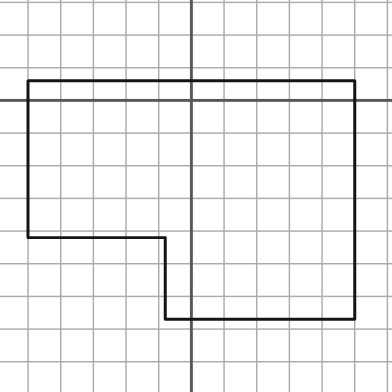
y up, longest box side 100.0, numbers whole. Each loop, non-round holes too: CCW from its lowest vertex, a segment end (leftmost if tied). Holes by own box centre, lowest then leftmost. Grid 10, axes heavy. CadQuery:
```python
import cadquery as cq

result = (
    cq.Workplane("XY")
    .moveTo(-8.0, -67.0)
    .lineTo(50.0, -67.0)
    .lineTo(50.0, 6.0)
    .lineTo(-50.0, 6.0)
    .lineTo(-50.0, -42.0)
    .lineTo(-8.0, -42.0)
    .close()
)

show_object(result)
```